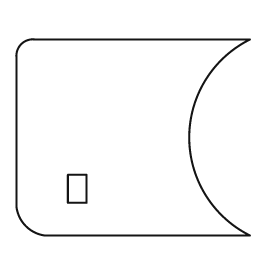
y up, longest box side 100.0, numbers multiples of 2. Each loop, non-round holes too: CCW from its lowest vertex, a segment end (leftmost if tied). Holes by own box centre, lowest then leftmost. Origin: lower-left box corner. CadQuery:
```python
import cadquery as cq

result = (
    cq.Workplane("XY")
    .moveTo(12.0, 0.0)
    .lineTo(100.0, 0.0)
    .threePointArc((74.0, 42.0), (100.0, 84.0))
    .lineTo(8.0, 84.0)
    .threePointArc((2.0, 82.0), (0.0, 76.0))
    .lineTo(0.0, 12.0)
    .threePointArc((4.0, 4.0), (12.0, 0.0))
    .close()
    .moveTo(22.0, 14.0)
    .lineTo(30.0, 14.0)
    .lineTo(30.0, 26.0)
    .lineTo(22.0, 26.0)
    .close()
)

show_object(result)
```